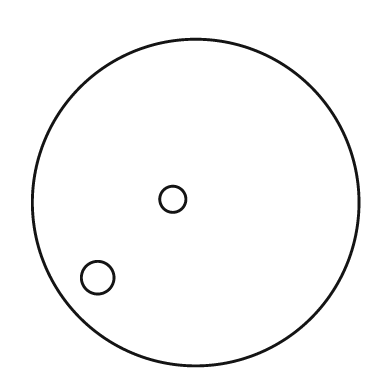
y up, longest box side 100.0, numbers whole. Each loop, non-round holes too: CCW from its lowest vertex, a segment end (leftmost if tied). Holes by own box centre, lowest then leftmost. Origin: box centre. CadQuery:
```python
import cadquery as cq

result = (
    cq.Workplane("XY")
    .moveTo(0.0, 0.0)
    .circle(50.0)
    .moveTo(-30.0, -23.0)
    .circle(5.0)
    .moveTo(-7.0, 1.0)
    .circle(4.0)
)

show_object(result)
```